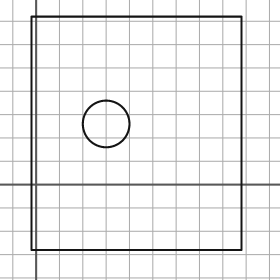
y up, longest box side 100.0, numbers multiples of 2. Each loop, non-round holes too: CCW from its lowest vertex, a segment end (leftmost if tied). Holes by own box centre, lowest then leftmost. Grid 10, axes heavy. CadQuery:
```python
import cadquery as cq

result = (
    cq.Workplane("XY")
    .moveTo(-2.0, -28.0)
    .lineTo(88.0, -28.0)
    .lineTo(88.0, 72.0)
    .lineTo(-2.0, 72.0)
    .close()
    .moveTo(30.0, 26.0)
    .circle(10.0)
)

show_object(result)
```